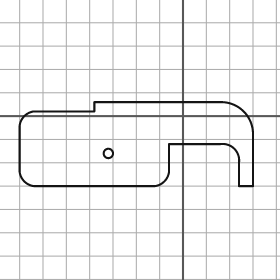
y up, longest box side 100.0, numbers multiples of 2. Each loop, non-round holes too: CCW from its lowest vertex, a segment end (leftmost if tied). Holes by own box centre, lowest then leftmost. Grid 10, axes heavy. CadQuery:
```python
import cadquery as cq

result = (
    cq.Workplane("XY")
    .moveTo(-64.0, -30.0)
    .lineTo(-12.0, -30.0)
    .threePointArc((-8.0, -28.0), (-6.0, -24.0))
    .lineTo(-6.0, -12.0)
    .lineTo(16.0, -12.0)
    .threePointArc((22.0, -14.0), (24.0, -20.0))
    .lineTo(24.0, -30.0)
    .lineTo(30.0, -30.0)
    .lineTo(30.0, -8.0)
    .threePointArc((26.0, 2.0), (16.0, 6.0))
    .lineTo(-38.0, 6.0)
    .lineTo(-38.0, 2.0)
    .lineTo(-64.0, 2.0)
    .threePointArc((-68.0, 0.0), (-70.0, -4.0))
    .lineTo(-70.0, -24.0)
    .threePointArc((-68.0, -28.0), (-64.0, -30.0))
    .close()
    .moveTo(-32.0, -16.0)
    .circle(2.0)
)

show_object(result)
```